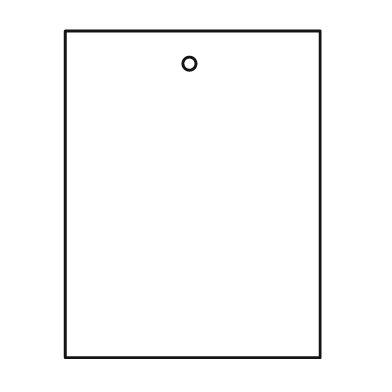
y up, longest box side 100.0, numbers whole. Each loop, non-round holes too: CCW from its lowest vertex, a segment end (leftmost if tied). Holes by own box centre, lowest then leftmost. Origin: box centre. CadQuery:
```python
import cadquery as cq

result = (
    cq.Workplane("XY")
    .moveTo(-39.0, -50.0)
    .lineTo(39.0, -50.0)
    .lineTo(39.0, 50.0)
    .lineTo(-39.0, 50.0)
    .close()
    .moveTo(-1.0, 40.0)
    .circle(2.0)
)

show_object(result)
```